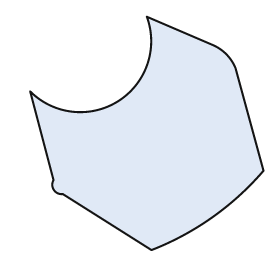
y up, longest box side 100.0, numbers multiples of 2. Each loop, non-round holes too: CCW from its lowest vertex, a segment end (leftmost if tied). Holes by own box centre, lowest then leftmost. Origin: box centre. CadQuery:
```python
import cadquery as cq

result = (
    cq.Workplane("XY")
    .moveTo(2.0, -50.0)
    .threePointArc((28.0, -36.0), (50.0, -16.0))
    .lineTo(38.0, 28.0)
    .threePointArc((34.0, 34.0), (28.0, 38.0))
    .lineTo(0.0, 50.0)
    .threePointArc((-12.0, 14.0), (-50.0, 18.0))
    .lineTo(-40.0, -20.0)
    .threePointArc((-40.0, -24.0), (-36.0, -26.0))
    .close()
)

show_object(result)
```